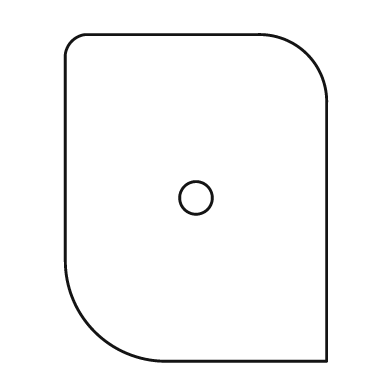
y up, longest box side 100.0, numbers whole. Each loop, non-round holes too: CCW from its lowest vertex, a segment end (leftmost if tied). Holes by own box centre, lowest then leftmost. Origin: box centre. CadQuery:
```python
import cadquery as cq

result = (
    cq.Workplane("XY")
    .moveTo(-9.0, -50.0)
    .lineTo(40.0, -50.0)
    .lineTo(40.0, 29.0)
    .threePointArc((34.0, 44.0), (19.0, 50.0))
    .lineTo(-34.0, 50.0)
    .threePointArc((-38.0, 48.0), (-40.0, 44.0))
    .lineTo(-40.0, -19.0)
    .threePointArc((-31.0, -41.0), (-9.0, -50.0))
    .close()
    .moveTo(0.0, 0.0)
    .circle(5.0)
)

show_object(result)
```